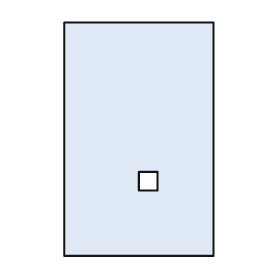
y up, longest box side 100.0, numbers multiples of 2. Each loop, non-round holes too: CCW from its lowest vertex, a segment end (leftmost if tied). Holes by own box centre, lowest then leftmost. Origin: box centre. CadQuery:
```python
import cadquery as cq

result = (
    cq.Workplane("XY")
    .moveTo(-32.0, -50.0)
    .lineTo(32.0, -50.0)
    .lineTo(32.0, 50.0)
    .lineTo(-32.0, 50.0)
    .close()
    .moveTo(0.0, -22.0)
    .lineTo(8.0, -22.0)
    .lineTo(8.0, -14.0)
    .lineTo(0.0, -14.0)
    .close()
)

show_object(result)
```